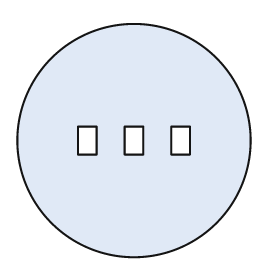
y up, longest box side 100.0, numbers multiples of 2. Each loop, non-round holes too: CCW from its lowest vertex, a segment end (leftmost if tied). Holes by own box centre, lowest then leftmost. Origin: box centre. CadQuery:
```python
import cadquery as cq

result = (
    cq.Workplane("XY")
    .moveTo(0.0, 0.0)
    .circle(50.0)
    .moveTo(-24.0, -6.0)
    .lineTo(-16.0, -6.0)
    .lineTo(-16.0, 6.0)
    .lineTo(-24.0, 6.0)
    .close()
    .moveTo(-4.0, -6.0)
    .lineTo(4.0, -6.0)
    .lineTo(4.0, 6.0)
    .lineTo(-4.0, 6.0)
    .close()
    .moveTo(16.0, -6.0)
    .lineTo(24.0, -6.0)
    .lineTo(24.0, 6.0)
    .lineTo(16.0, 6.0)
    .close()
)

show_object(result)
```